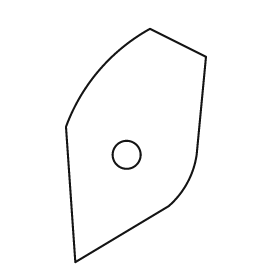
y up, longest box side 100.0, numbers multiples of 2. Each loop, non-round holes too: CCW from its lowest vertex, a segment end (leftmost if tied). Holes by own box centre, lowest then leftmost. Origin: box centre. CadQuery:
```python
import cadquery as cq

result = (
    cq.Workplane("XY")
    .moveTo(-26.0, -50.0)
    .lineTo(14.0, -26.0)
    .threePointArc((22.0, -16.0), (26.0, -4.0))
    .lineTo(30.0, 38.0)
    .lineTo(6.0, 50.0)
    .threePointArc((-16.0, 32.0), (-30.0, 8.0))
    .close()
    .moveTo(-4.0, -4.0)
    .circle(6.0)
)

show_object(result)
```